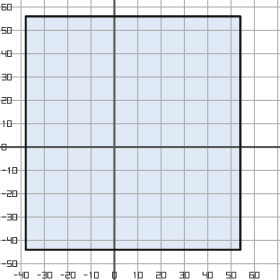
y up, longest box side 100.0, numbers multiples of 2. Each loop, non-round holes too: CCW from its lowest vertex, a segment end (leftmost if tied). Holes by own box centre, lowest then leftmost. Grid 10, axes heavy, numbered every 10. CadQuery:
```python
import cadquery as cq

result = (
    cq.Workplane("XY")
    .moveTo(-38.0, -44.0)
    .lineTo(54.0, -44.0)
    .lineTo(54.0, 56.0)
    .lineTo(-38.0, 56.0)
    .close()
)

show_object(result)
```